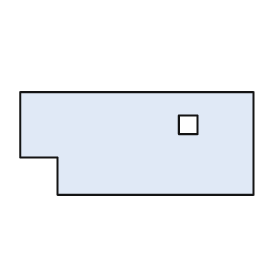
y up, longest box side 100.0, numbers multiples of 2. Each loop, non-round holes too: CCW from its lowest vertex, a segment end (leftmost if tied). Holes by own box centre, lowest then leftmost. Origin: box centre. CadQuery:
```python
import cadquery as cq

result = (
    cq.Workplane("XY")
    .moveTo(-34.0, -22.0)
    .lineTo(50.0, -22.0)
    .lineTo(50.0, 22.0)
    .lineTo(-50.0, 22.0)
    .lineTo(-50.0, -6.0)
    .lineTo(-34.0, -6.0)
    .close()
    .moveTo(18.0, 4.0)
    .lineTo(26.0, 4.0)
    .lineTo(26.0, 12.0)
    .lineTo(18.0, 12.0)
    .close()
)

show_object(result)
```